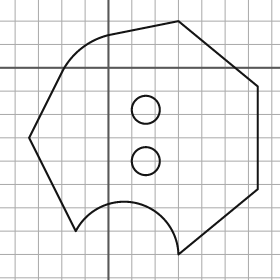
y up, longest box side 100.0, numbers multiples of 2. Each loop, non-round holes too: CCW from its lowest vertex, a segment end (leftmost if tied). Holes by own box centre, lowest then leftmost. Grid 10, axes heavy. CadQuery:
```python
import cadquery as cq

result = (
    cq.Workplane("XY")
    .moveTo(30.0, -80.0)
    .lineTo(64.0, -52.0)
    .lineTo(64.0, -8.0)
    .lineTo(30.0, 20.0)
    .lineTo(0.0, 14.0)
    .threePointArc((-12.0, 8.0), (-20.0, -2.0))
    .lineTo(-34.0, -30.0)
    .lineTo(-14.0, -70.0)
    .threePointArc((12.0, -58.0), (30.0, -80.0))
    .close()
    .moveTo(16.0, -40.0)
    .circle(6.0)
    .moveTo(16.0, -18.0)
    .circle(6.0)
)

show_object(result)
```